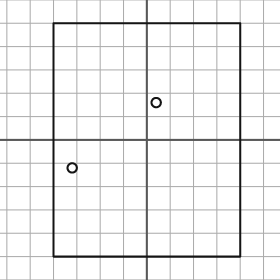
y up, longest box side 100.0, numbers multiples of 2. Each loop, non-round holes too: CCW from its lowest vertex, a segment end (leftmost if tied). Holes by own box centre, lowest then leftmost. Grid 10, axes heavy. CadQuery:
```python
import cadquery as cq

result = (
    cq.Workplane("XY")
    .moveTo(-40.0, -50.0)
    .lineTo(40.0, -50.0)
    .lineTo(40.0, 50.0)
    .lineTo(-40.0, 50.0)
    .close()
    .moveTo(-32.0, -12.0)
    .circle(2.0)
    .moveTo(4.0, 16.0)
    .circle(2.0)
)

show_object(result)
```